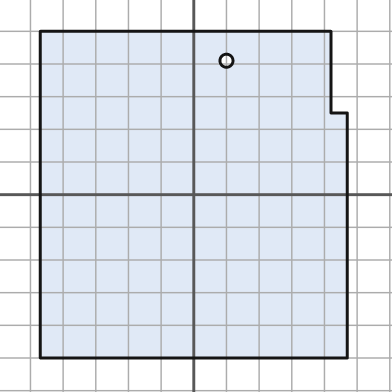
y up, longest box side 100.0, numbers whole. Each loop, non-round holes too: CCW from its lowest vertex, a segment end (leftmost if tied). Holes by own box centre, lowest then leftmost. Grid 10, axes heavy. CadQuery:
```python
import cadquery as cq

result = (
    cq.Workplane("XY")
    .moveTo(-47.0, -50.0)
    .lineTo(47.0, -50.0)
    .lineTo(47.0, 25.0)
    .lineTo(42.0, 25.0)
    .lineTo(42.0, 50.0)
    .lineTo(-47.0, 50.0)
    .close()
    .moveTo(10.0, 41.0)
    .circle(2.0)
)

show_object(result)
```